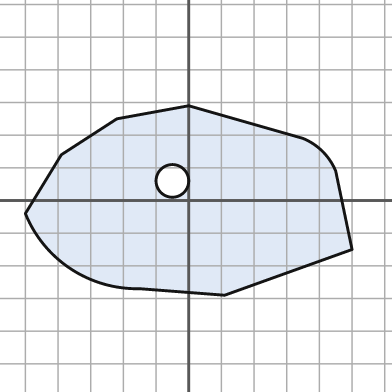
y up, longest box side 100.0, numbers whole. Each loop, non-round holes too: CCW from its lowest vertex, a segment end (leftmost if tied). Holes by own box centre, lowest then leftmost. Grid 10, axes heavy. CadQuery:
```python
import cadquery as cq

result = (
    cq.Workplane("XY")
    .moveTo(11.0, -29.0)
    .lineTo(50.0, -15.0)
    .lineTo(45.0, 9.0)
    .threePointArc((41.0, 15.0), (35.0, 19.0))
    .lineTo(0.0, 29.0)
    .lineTo(-22.0, 25.0)
    .lineTo(-39.0, 14.0)
    .lineTo(-50.0, -4.0)
    .threePointArc((-36.0, -21.0), (-15.0, -27.0))
    .close()
    .moveTo(-5.0, 6.0)
    .circle(5.0)
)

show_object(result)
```